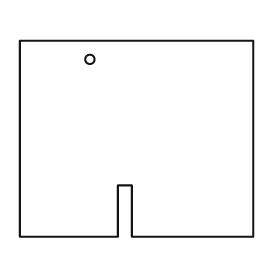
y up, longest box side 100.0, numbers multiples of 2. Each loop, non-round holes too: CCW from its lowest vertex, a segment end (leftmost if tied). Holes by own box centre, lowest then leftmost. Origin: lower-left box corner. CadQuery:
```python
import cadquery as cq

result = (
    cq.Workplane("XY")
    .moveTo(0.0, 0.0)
    .lineTo(42.0, 0.0)
    .lineTo(42.0, 22.0)
    .lineTo(48.0, 22.0)
    .lineTo(48.0, 0.0)
    .lineTo(100.0, 0.0)
    .lineTo(100.0, 84.0)
    .lineTo(0.0, 84.0)
    .close()
    .moveTo(30.0, 76.0)
    .circle(2.0)
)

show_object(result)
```